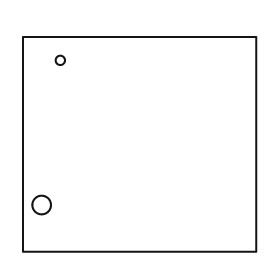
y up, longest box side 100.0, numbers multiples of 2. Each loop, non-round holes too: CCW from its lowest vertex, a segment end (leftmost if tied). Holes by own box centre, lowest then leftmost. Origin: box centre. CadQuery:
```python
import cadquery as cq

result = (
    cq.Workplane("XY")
    .moveTo(-50.0, -46.0)
    .lineTo(50.0, -46.0)
    .lineTo(50.0, 46.0)
    .lineTo(-50.0, 46.0)
    .close()
    .moveTo(-42.0, -26.0)
    .circle(4.0)
    .moveTo(-34.0, 36.0)
    .circle(2.0)
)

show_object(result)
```